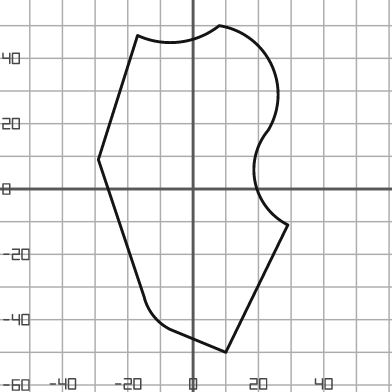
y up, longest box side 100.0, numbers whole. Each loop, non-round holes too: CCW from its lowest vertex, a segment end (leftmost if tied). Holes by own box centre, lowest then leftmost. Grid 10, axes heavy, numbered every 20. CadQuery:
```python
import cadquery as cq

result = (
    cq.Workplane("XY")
    .moveTo(10.0, -50.0)
    .lineTo(29.0, -11.0)
    .threePointArc((19.0, 2.0), (23.0, 18.0))
    .threePointArc((24.0, 38.0), (8.0, 50.0))
    .threePointArc((-4.0, 45.0), (-17.0, 47.0))
    .lineTo(-29.0, 9.0)
    .lineTo(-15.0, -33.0)
    .threePointArc((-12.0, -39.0), (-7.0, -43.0))
    .close()
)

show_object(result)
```